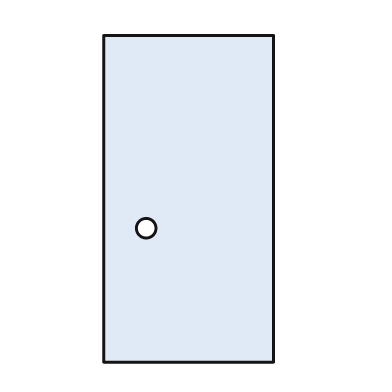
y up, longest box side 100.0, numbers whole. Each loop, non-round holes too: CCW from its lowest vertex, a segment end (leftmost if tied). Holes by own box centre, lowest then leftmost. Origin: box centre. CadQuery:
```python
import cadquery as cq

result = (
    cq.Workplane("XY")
    .moveTo(-26.0, -50.0)
    .lineTo(26.0, -50.0)
    .lineTo(26.0, 50.0)
    .lineTo(-26.0, 50.0)
    .close()
    .moveTo(-13.0, -9.0)
    .circle(3.0)
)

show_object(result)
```